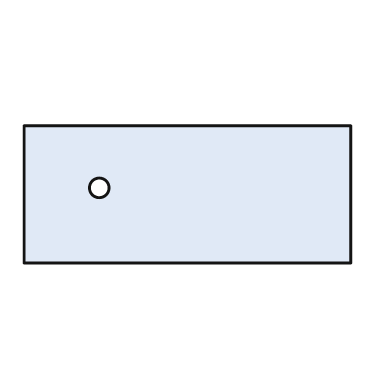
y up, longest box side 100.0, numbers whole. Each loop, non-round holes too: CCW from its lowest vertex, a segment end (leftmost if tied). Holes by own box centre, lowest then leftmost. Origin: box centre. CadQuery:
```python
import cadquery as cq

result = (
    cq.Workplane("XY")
    .moveTo(-50.0, -21.0)
    .lineTo(50.0, -21.0)
    .lineTo(50.0, 21.0)
    .lineTo(-50.0, 21.0)
    .close()
    .moveTo(-27.0, 2.0)
    .circle(3.0)
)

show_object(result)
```